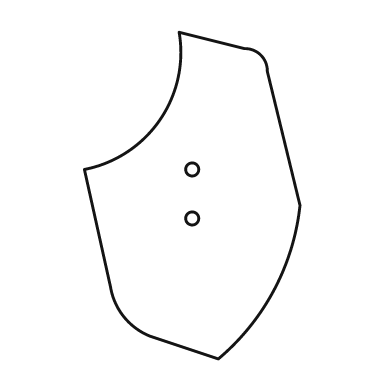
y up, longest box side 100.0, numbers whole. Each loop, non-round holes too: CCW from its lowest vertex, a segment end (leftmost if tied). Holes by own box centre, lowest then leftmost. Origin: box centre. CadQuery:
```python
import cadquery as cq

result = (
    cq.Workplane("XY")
    .moveTo(8.0, -50.0)
    .threePointArc((25.0, -29.0), (33.0, -3.0))
    .lineTo(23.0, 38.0)
    .threePointArc((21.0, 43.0), (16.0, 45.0))
    .lineTo(-4.0, 50.0)
    .threePointArc((-10.0, 23.0), (-33.0, 8.0))
    .lineTo(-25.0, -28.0)
    .threePointArc((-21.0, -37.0), (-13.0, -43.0))
    .close()
    .moveTo(0.0, -7.0)
    .circle(2.0)
    .moveTo(0.0, 8.0)
    .circle(2.0)
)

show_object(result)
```